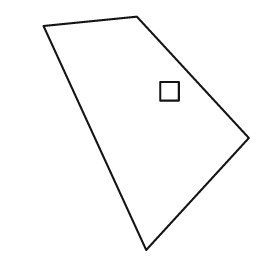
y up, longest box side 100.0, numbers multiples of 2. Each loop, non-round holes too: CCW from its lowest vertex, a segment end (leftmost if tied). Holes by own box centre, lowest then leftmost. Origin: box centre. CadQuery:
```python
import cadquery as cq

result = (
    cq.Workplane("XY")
    .moveTo(0.0, -50.0)
    .lineTo(44.0, -2.0)
    .lineTo(-4.0, 50.0)
    .lineTo(-44.0, 46.0)
    .close()
    .moveTo(6.0, 14.0)
    .lineTo(14.0, 14.0)
    .lineTo(14.0, 22.0)
    .lineTo(6.0, 22.0)
    .close()
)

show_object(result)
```